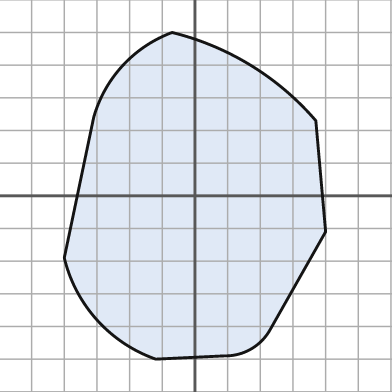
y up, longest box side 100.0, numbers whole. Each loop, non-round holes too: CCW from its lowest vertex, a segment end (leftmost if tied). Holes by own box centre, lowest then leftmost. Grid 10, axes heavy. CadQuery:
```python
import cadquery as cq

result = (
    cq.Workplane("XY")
    .moveTo(-12.0, -50.0)
    .lineTo(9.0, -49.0)
    .threePointArc((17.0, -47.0), (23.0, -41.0))
    .lineTo(40.0, -11.0)
    .lineTo(37.0, 23.0)
    .threePointArc((17.0, 40.0), (-7.0, 50.0))
    .threePointArc((-22.0, 40.0), (-31.0, 24.0))
    .lineTo(-40.0, -19.0)
    .threePointArc((-30.0, -38.0), (-12.0, -50.0))
    .close()
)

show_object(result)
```